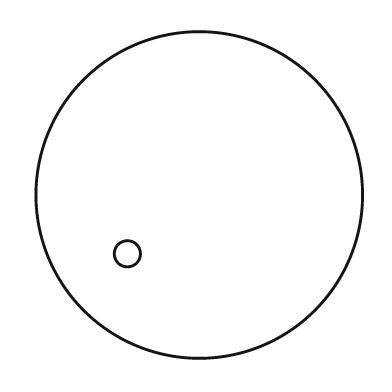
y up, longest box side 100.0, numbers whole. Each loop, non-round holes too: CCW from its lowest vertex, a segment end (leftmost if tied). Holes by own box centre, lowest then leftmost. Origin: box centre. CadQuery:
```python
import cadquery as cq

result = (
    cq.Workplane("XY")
    .moveTo(0.0, 0.0)
    .circle(50.0)
    .moveTo(-22.0, -18.0)
    .circle(4.0)
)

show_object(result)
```